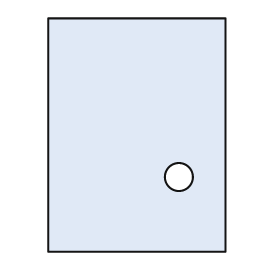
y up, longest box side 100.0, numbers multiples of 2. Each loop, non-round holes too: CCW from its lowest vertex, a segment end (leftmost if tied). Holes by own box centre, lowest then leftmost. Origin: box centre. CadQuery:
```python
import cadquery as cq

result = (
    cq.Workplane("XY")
    .moveTo(-38.0, -50.0)
    .lineTo(38.0, -50.0)
    .lineTo(38.0, 50.0)
    .lineTo(-38.0, 50.0)
    .close()
    .moveTo(18.0, -18.0)
    .circle(6.0)
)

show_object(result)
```